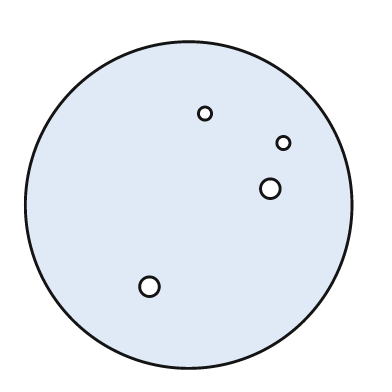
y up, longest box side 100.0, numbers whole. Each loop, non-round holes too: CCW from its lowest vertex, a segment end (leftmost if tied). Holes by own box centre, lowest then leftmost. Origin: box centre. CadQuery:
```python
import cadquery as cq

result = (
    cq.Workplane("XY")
    .moveTo(0.0, 0.0)
    .circle(50.0)
    .moveTo(-12.0, -25.0)
    .circle(3.0)
    .moveTo(25.0, 5.0)
    .circle(3.0)
    .moveTo(29.0, 19.0)
    .circle(2.0)
    .moveTo(5.0, 28.0)
    .circle(2.0)
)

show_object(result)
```